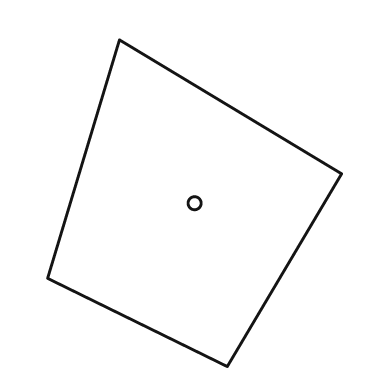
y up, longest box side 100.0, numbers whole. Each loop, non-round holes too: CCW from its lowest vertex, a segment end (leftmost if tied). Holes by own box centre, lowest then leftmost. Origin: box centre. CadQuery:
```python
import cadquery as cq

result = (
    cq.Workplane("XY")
    .moveTo(10.0, -50.0)
    .lineTo(45.0, 9.0)
    .lineTo(-23.0, 50.0)
    .lineTo(-45.0, -23.0)
    .close()
    .moveTo(0.0, 0.0)
    .circle(2.0)
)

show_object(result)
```